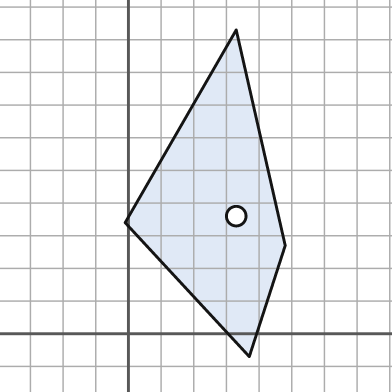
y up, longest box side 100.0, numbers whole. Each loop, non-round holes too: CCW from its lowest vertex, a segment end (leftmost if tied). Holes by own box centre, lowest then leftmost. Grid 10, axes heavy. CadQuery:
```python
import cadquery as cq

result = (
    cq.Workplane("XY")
    .moveTo(37.0, -7.0)
    .lineTo(48.0, 27.0)
    .lineTo(33.0, 93.0)
    .lineTo(-1.0, 34.0)
    .close()
    .moveTo(33.0, 36.0)
    .circle(3.0)
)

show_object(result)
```